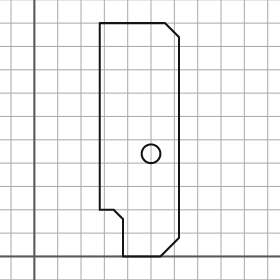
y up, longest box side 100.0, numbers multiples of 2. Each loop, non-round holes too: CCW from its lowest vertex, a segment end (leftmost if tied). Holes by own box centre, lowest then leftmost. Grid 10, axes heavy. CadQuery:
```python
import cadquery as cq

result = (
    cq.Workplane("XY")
    .moveTo(38.0, 0.0)
    .lineTo(54.0, 0.0)
    .lineTo(62.0, 8.0)
    .lineTo(62.0, 94.0)
    .lineTo(56.0, 100.0)
    .lineTo(28.0, 100.0)
    .lineTo(28.0, 20.0)
    .lineTo(34.0, 20.0)
    .lineTo(38.0, 16.0)
    .close()
    .moveTo(50.0, 44.0)
    .circle(4.0)
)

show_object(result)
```